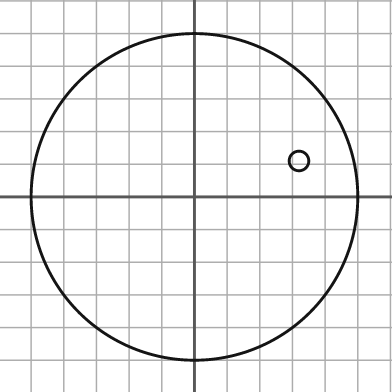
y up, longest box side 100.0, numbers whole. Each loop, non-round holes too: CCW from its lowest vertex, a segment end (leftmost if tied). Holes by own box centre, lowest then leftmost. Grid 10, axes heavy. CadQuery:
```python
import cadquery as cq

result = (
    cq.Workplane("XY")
    .moveTo(0.0, 0.0)
    .circle(50.0)
    .moveTo(32.0, 11.0)
    .circle(3.0)
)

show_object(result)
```